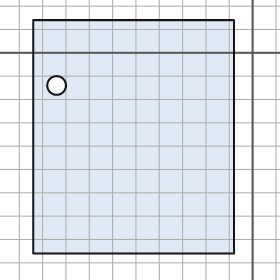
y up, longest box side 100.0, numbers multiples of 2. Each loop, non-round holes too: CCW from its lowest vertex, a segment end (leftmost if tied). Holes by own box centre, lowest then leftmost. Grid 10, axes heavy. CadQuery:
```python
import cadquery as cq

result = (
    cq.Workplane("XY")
    .moveTo(-94.0, -86.0)
    .lineTo(-8.0, -86.0)
    .lineTo(-8.0, 14.0)
    .lineTo(-94.0, 14.0)
    .close()
    .moveTo(-84.0, -14.0)
    .circle(4.0)
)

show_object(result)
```